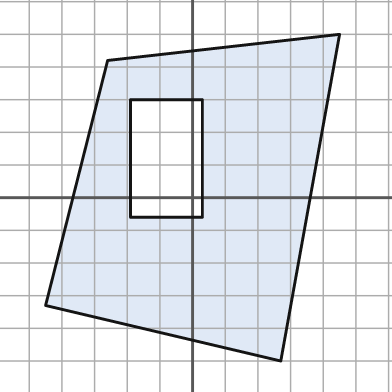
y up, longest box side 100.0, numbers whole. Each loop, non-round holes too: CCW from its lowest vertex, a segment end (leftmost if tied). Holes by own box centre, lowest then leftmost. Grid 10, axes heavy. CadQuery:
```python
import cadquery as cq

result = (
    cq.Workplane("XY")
    .moveTo(27.0, -50.0)
    .lineTo(45.0, 50.0)
    .lineTo(-26.0, 42.0)
    .lineTo(-45.0, -33.0)
    .close()
    .moveTo(-19.0, -6.0)
    .lineTo(3.0, -6.0)
    .lineTo(3.0, 30.0)
    .lineTo(-19.0, 30.0)
    .close()
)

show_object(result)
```